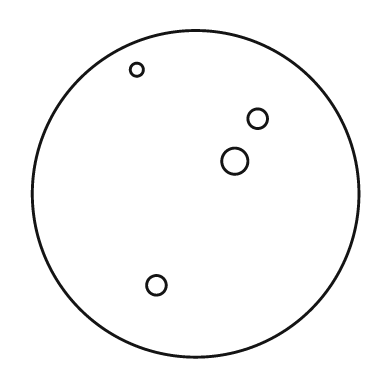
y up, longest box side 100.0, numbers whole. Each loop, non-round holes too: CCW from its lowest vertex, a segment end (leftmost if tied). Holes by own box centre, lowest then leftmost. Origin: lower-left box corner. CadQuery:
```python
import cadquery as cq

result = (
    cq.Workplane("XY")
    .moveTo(50.0, 50.0)
    .circle(50.0)
    .moveTo(38.0, 22.0)
    .circle(3.0)
    .moveTo(62.0, 60.0)
    .circle(4.0)
    .moveTo(69.0, 73.0)
    .circle(3.0)
    .moveTo(32.0, 88.0)
    .circle(2.0)
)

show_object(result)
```